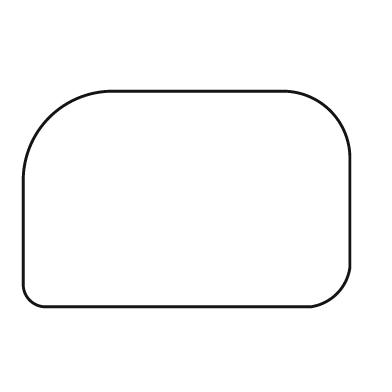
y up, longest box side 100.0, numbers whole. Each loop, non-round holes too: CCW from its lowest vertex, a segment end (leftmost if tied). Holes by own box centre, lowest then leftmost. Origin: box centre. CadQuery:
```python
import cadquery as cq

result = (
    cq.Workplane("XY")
    .moveTo(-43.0, -33.0)
    .lineTo(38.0, -33.0)
    .threePointArc((46.0, -29.0), (50.0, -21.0))
    .lineTo(50.0, 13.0)
    .threePointArc((44.0, 27.0), (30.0, 33.0))
    .lineTo(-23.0, 33.0)
    .threePointArc((-42.0, 25.0), (-50.0, 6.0))
    .lineTo(-50.0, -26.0)
    .threePointArc((-48.0, -31.0), (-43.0, -33.0))
    .close()
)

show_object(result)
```